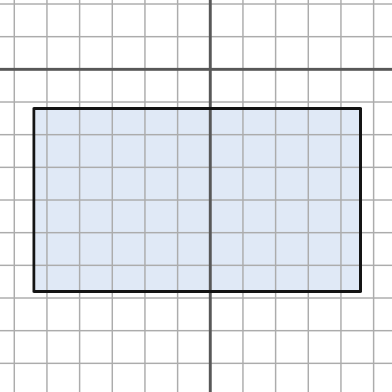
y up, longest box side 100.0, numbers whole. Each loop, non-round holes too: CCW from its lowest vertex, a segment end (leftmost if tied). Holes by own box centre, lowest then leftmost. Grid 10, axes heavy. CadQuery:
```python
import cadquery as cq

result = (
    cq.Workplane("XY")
    .moveTo(-54.0, -68.0)
    .lineTo(46.0, -68.0)
    .lineTo(46.0, -12.0)
    .lineTo(-54.0, -12.0)
    .close()
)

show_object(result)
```